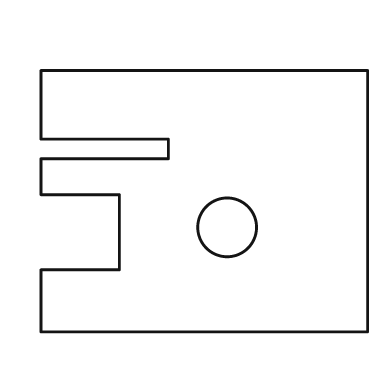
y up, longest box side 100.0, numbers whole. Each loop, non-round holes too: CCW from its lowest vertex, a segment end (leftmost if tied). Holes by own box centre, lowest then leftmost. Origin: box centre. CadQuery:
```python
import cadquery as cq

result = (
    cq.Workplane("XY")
    .moveTo(-50.0, -40.0)
    .lineTo(50.0, -40.0)
    .lineTo(50.0, 40.0)
    .lineTo(-50.0, 40.0)
    .lineTo(-50.0, 19.0)
    .lineTo(-11.0, 19.0)
    .lineTo(-11.0, 13.0)
    .lineTo(-50.0, 13.0)
    .lineTo(-50.0, 2.0)
    .lineTo(-26.0, 2.0)
    .lineTo(-26.0, -21.0)
    .lineTo(-50.0, -21.0)
    .close()
    .moveTo(7.0, -8.0)
    .circle(9.0)
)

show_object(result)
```